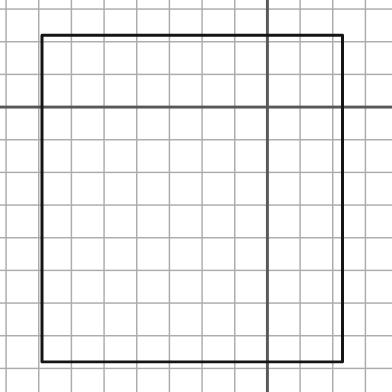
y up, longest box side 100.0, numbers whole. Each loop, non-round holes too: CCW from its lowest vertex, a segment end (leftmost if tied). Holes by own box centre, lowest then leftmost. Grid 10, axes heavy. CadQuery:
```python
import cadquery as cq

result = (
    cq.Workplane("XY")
    .moveTo(-69.0, -78.0)
    .lineTo(23.0, -78.0)
    .lineTo(23.0, 22.0)
    .lineTo(-69.0, 22.0)
    .close()
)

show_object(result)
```